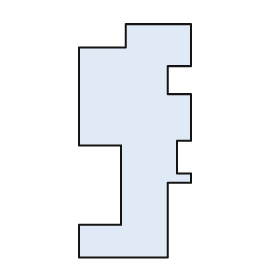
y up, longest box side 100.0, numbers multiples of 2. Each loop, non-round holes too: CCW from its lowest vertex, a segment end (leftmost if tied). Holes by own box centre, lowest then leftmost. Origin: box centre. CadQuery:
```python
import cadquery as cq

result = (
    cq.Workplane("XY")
    .moveTo(-24.0, -50.0)
    .lineTo(14.0, -50.0)
    .lineTo(14.0, -18.0)
    .lineTo(24.0, -18.0)
    .lineTo(24.0, -14.0)
    .lineTo(18.0, -14.0)
    .lineTo(18.0, 0.0)
    .lineTo(24.0, 0.0)
    .lineTo(24.0, 20.0)
    .lineTo(14.0, 20.0)
    .lineTo(14.0, 32.0)
    .lineTo(24.0, 32.0)
    .lineTo(24.0, 50.0)
    .lineTo(-4.0, 50.0)
    .lineTo(-4.0, 40.0)
    .lineTo(-24.0, 40.0)
    .lineTo(-24.0, -2.0)
    .lineTo(-6.0, -2.0)
    .lineTo(-6.0, -36.0)
    .lineTo(-24.0, -36.0)
    .close()
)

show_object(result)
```